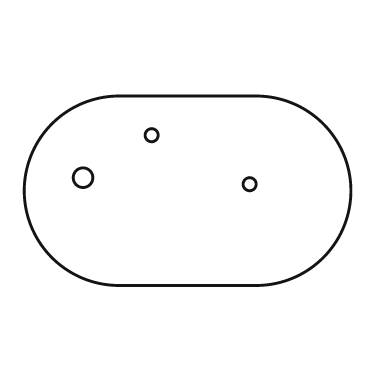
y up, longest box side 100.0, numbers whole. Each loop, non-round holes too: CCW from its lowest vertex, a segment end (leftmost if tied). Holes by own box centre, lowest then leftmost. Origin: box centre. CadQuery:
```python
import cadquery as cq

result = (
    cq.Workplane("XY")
    .moveTo(-21.0, -29.0)
    .lineTo(21.0, -29.0)
    .threePointArc((50.0, 0.0), (21.0, 29.0))
    .lineTo(-21.0, 29.0)
    .threePointArc((-50.0, 0.0), (-21.0, -29.0))
    .close()
    .moveTo(19.0, 2.0)
    .circle(2.0)
    .moveTo(-32.0, 4.0)
    .circle(3.0)
    .moveTo(-11.0, 17.0)
    .circle(2.0)
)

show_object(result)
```